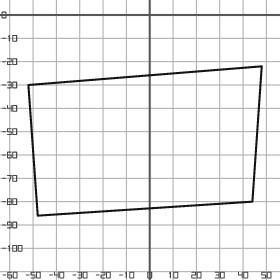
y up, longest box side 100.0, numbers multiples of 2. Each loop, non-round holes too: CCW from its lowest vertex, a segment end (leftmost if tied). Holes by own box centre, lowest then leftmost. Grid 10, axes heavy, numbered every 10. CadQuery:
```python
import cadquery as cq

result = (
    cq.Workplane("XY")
    .moveTo(-48.0, -86.0)
    .lineTo(44.0, -80.0)
    .lineTo(48.0, -22.0)
    .lineTo(-52.0, -30.0)
    .close()
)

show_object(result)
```